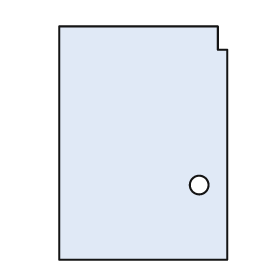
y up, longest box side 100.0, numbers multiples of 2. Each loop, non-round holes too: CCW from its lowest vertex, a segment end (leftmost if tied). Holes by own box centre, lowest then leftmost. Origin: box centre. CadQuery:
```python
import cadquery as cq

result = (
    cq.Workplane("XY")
    .moveTo(-36.0, -50.0)
    .lineTo(36.0, -50.0)
    .lineTo(36.0, 40.0)
    .lineTo(32.0, 40.0)
    .lineTo(32.0, 50.0)
    .lineTo(-36.0, 50.0)
    .close()
    .moveTo(24.0, -18.0)
    .circle(4.0)
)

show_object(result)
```